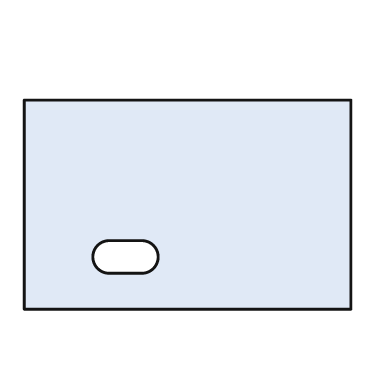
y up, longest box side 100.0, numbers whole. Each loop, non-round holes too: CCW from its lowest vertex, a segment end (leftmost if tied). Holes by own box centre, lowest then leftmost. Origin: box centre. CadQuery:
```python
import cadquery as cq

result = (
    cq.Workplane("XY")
    .moveTo(-50.0, -32.0)
    .lineTo(50.0, -32.0)
    .lineTo(50.0, 32.0)
    .lineTo(-50.0, 32.0)
    .close()
    .moveTo(-24.0, -21.0)
    .lineTo(-14.0, -21.0)
    .threePointArc((-9.0, -16.0), (-14.0, -11.0))
    .lineTo(-24.0, -11.0)
    .threePointArc((-29.0, -16.0), (-24.0, -21.0))
    .close()
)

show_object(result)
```